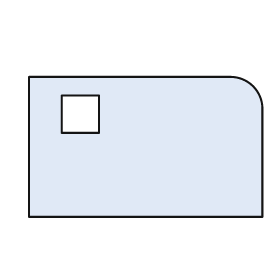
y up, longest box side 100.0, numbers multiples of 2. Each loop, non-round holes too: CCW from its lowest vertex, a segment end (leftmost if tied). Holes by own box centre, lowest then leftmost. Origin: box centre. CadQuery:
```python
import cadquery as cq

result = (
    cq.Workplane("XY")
    .moveTo(-50.0, -30.0)
    .lineTo(50.0, -30.0)
    .lineTo(50.0, 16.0)
    .threePointArc((46.0, 26.0), (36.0, 30.0))
    .lineTo(-50.0, 30.0)
    .close()
    .moveTo(-36.0, 6.0)
    .lineTo(-20.0, 6.0)
    .lineTo(-20.0, 22.0)
    .lineTo(-36.0, 22.0)
    .close()
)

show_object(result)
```